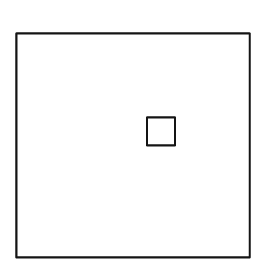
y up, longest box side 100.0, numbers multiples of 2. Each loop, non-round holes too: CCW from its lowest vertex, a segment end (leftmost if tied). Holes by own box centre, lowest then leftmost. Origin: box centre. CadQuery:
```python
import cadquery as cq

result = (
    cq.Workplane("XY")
    .moveTo(-50.0, -48.0)
    .lineTo(50.0, -48.0)
    .lineTo(50.0, 48.0)
    .lineTo(-50.0, 48.0)
    .close()
    .moveTo(6.0, 0.0)
    .lineTo(18.0, 0.0)
    .lineTo(18.0, 12.0)
    .lineTo(6.0, 12.0)
    .close()
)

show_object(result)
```